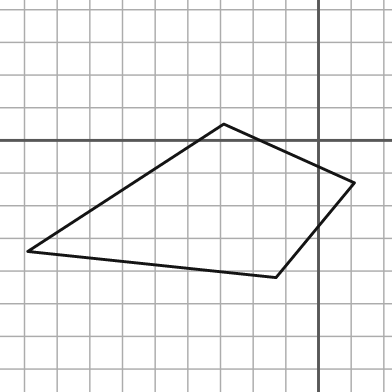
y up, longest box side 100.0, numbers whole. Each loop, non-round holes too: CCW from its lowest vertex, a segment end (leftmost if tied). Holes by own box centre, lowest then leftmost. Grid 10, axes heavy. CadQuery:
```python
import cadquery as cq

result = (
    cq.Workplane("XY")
    .moveTo(-13.0, -42.0)
    .lineTo(11.0, -13.0)
    .lineTo(-29.0, 5.0)
    .lineTo(-89.0, -34.0)
    .close()
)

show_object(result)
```